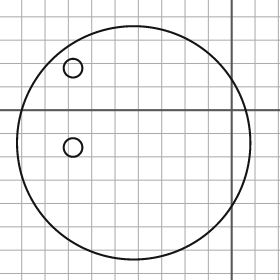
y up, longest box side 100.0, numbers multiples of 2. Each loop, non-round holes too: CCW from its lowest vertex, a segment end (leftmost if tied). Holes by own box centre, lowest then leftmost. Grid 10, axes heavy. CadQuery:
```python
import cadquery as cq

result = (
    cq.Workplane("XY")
    .moveTo(-42.0, -14.0)
    .circle(50.0)
    .moveTo(-68.0, -16.0)
    .circle(4.0)
    .moveTo(-68.0, 18.0)
    .circle(4.0)
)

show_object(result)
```